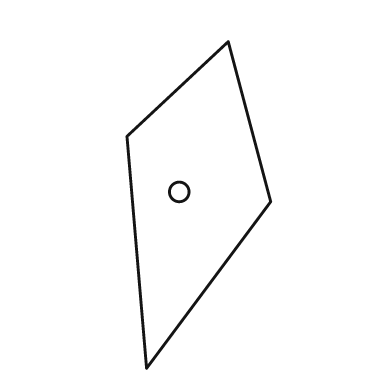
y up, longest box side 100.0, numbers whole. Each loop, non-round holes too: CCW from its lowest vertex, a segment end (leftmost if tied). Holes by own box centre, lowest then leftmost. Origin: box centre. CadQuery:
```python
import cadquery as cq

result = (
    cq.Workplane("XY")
    .moveTo(-16.0, -50.0)
    .lineTo(22.0, 1.0)
    .lineTo(9.0, 50.0)
    .lineTo(-22.0, 21.0)
    .close()
    .moveTo(-6.0, 4.0)
    .circle(3.0)
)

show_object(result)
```